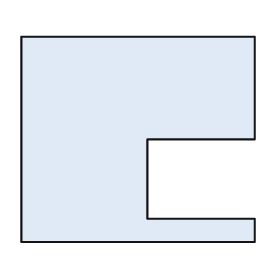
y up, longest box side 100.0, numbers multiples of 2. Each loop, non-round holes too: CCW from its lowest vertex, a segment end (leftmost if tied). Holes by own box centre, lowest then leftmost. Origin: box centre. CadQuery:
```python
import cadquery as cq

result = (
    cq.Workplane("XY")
    .moveTo(-50.0, -44.0)
    .lineTo(50.0, -44.0)
    .lineTo(50.0, -34.0)
    .lineTo(4.0, -34.0)
    .lineTo(4.0, 0.0)
    .lineTo(50.0, 0.0)
    .lineTo(50.0, 44.0)
    .lineTo(-50.0, 44.0)
    .close()
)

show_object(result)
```